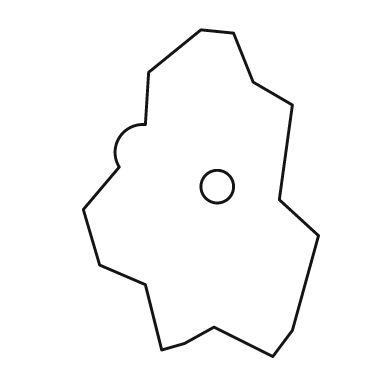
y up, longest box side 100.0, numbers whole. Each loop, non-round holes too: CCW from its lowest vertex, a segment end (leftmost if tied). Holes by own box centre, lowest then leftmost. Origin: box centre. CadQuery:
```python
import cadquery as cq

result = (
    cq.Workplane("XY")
    .moveTo(22.0, -50.0)
    .lineTo(28.0, -42.0)
    .lineTo(36.0, -13.0)
    .lineTo(24.0, -2.0)
    .lineTo(28.0, 27.0)
    .lineTo(16.0, 34.0)
    .lineTo(10.0, 49.0)
    .lineTo(0.0, 50.0)
    .lineTo(-16.0, 37.0)
    .lineTo(-17.0, 21.0)
    .threePointArc((-25.0, 17.0), (-25.0, 8.0))
    .lineTo(-36.0, -5.0)
    .lineTo(-31.0, -22.0)
    .lineTo(-17.0, -28.0)
    .lineTo(-12.0, -48.0)
    .lineTo(-5.0, -46.0)
    .lineTo(4.0, -41.0)
    .close()
    .moveTo(5.0, 2.0)
    .circle(5.0)
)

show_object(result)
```